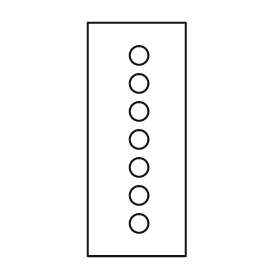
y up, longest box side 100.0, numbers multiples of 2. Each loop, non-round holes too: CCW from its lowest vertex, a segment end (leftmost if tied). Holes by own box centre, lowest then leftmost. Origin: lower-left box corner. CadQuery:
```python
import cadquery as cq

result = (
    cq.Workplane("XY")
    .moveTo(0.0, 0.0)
    .lineTo(42.0, 0.0)
    .lineTo(42.0, 100.0)
    .lineTo(0.0, 100.0)
    .close()
    .moveTo(22.0, 14.0)
    .circle(4.0)
    .moveTo(22.0, 26.0)
    .circle(4.0)
    .moveTo(22.0, 38.0)
    .circle(4.0)
    .moveTo(22.0, 50.0)
    .circle(4.0)
    .moveTo(22.0, 62.0)
    .circle(4.0)
    .moveTo(22.0, 74.0)
    .circle(4.0)
    .moveTo(22.0, 86.0)
    .circle(4.0)
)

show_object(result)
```